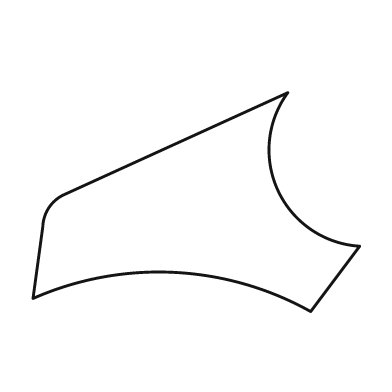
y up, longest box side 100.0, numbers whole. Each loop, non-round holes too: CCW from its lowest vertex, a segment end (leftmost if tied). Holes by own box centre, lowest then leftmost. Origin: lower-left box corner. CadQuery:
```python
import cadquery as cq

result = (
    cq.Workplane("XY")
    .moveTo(85.0, 0.0)
    .lineTo(100.0, 20.0)
    .threePointArc((75.0, 37.0), (78.0, 67.0))
    .lineTo(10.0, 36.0)
    .threePointArc((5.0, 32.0), (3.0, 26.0))
    .lineTo(0.0, 4.0)
    .threePointArc((43.0, 12.0), (85.0, 0.0))
    .close()
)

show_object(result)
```